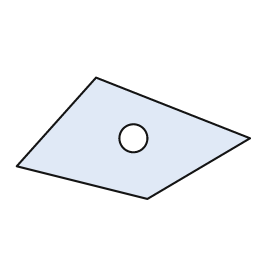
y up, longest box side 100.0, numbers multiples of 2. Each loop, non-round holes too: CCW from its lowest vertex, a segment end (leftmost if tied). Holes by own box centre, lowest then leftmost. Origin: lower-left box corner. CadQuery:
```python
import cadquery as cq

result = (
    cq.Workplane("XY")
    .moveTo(56.0, 0.0)
    .lineTo(100.0, 26.0)
    .lineTo(34.0, 52.0)
    .lineTo(0.0, 14.0)
    .close()
    .moveTo(50.0, 26.0)
    .circle(6.0)
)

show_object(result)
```